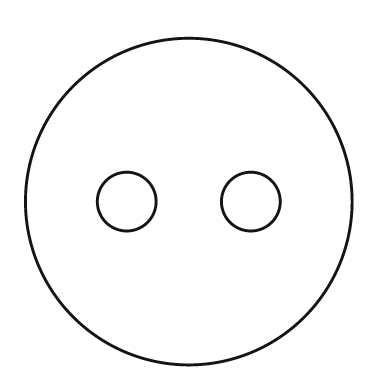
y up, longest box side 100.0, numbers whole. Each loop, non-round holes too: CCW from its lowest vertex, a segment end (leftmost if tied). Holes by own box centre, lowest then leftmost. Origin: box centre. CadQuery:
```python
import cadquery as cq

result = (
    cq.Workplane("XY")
    .moveTo(0.0, 0.0)
    .circle(50.0)
    .moveTo(-19.0, 0.0)
    .circle(9.0)
    .moveTo(19.0, 0.0)
    .circle(9.0)
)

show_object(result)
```